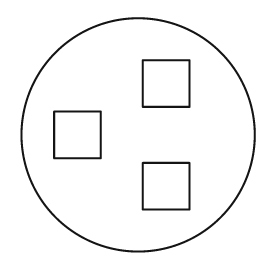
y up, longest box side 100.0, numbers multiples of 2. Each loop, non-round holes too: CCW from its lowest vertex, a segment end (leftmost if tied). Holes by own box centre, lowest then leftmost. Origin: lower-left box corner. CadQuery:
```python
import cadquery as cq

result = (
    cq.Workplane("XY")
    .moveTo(50.0, 50.0)
    .circle(50.0)
    .moveTo(52.0, 18.0)
    .lineTo(72.0, 18.0)
    .lineTo(72.0, 38.0)
    .lineTo(52.0, 38.0)
    .close()
    .moveTo(14.0, 40.0)
    .lineTo(34.0, 40.0)
    .lineTo(34.0, 60.0)
    .lineTo(14.0, 60.0)
    .close()
    .moveTo(52.0, 62.0)
    .lineTo(72.0, 62.0)
    .lineTo(72.0, 82.0)
    .lineTo(52.0, 82.0)
    .close()
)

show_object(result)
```